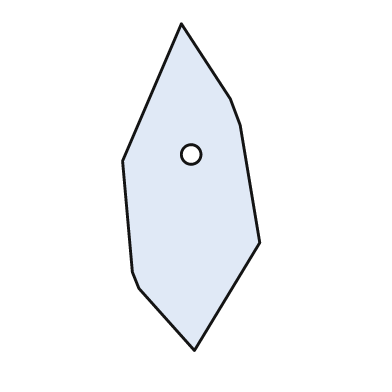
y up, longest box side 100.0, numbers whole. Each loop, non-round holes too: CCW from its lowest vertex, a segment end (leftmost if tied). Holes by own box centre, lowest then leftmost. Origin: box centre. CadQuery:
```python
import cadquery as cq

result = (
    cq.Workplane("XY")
    .moveTo(1.0, -50.0)
    .lineTo(21.0, -17.0)
    .lineTo(15.0, 19.0)
    .lineTo(12.0, 27.0)
    .lineTo(-3.0, 50.0)
    .lineTo(-21.0, 8.0)
    .lineTo(-18.0, -26.0)
    .lineTo(-16.0, -31.0)
    .close()
    .moveTo(0.0, 10.0)
    .circle(3.0)
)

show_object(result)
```